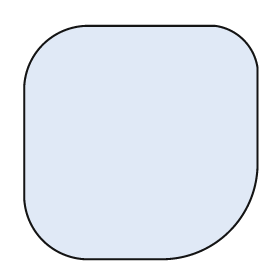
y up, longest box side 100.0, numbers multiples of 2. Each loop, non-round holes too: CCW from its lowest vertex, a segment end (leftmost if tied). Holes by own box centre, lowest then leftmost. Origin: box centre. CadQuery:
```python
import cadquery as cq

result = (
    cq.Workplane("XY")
    .moveTo(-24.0, -50.0)
    .lineTo(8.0, -50.0)
    .threePointArc((38.0, -38.0), (50.0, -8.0))
    .lineTo(50.0, 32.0)
    .threePointArc((44.0, 44.0), (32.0, 50.0))
    .lineTo(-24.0, 50.0)
    .threePointArc((-42.0, 42.0), (-50.0, 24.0))
    .lineTo(-50.0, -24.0)
    .threePointArc((-42.0, -42.0), (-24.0, -50.0))
    .close()
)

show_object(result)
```